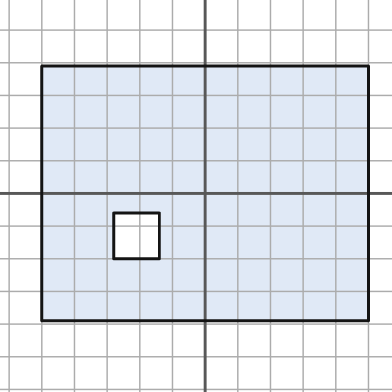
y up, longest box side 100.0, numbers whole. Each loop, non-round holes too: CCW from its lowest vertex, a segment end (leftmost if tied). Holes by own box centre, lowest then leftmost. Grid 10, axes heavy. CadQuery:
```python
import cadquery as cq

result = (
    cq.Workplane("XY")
    .moveTo(-50.0, -39.0)
    .lineTo(50.0, -39.0)
    .lineTo(50.0, 39.0)
    .lineTo(-50.0, 39.0)
    .close()
    .moveTo(-28.0, -20.0)
    .lineTo(-14.0, -20.0)
    .lineTo(-14.0, -6.0)
    .lineTo(-28.0, -6.0)
    .close()
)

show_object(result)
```